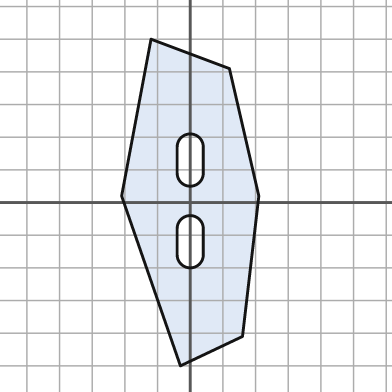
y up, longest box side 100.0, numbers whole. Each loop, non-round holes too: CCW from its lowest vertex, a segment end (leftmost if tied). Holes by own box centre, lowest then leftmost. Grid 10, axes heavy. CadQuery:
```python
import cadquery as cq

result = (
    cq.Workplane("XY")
    .moveTo(-3.0, -50.0)
    .lineTo(16.0, -41.0)
    .lineTo(21.0, 2.0)
    .lineTo(12.0, 41.0)
    .lineTo(-12.0, 50.0)
    .lineTo(-21.0, 2.0)
    .close()
    .moveTo(-4.0, -16.0)
    .threePointArc((0.0, -20.0), (4.0, -16.0))
    .lineTo(4.0, -8.0)
    .threePointArc((0.0, -4.0), (-4.0, -8.0))
    .close()
    .moveTo(-4.0, 9.0)
    .threePointArc((0.0, 5.0), (4.0, 9.0))
    .lineTo(4.0, 17.0)
    .threePointArc((0.0, 21.0), (-4.0, 17.0))
    .close()
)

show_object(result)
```